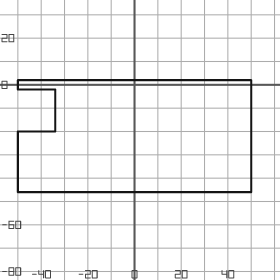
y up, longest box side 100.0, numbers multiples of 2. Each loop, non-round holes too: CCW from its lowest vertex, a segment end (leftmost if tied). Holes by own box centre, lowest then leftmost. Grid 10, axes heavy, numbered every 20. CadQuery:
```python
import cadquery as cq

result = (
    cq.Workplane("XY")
    .moveTo(-50.0, -46.0)
    .lineTo(50.0, -46.0)
    .lineTo(50.0, 2.0)
    .lineTo(-50.0, 2.0)
    .lineTo(-50.0, -2.0)
    .lineTo(-34.0, -2.0)
    .lineTo(-34.0, -20.0)
    .lineTo(-50.0, -20.0)
    .close()
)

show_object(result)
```